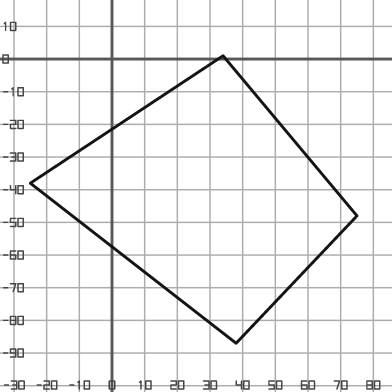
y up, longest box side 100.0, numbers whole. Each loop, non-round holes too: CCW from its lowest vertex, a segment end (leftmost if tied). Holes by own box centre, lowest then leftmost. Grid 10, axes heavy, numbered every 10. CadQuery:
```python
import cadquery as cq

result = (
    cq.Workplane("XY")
    .moveTo(38.0, -87.0)
    .lineTo(75.0, -48.0)
    .lineTo(34.0, 1.0)
    .lineTo(-25.0, -38.0)
    .close()
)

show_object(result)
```